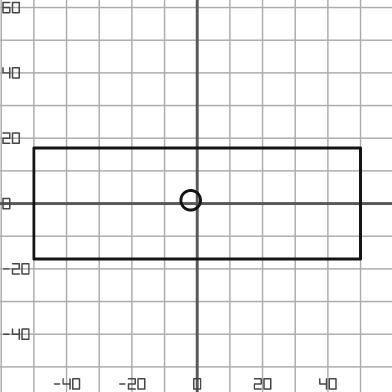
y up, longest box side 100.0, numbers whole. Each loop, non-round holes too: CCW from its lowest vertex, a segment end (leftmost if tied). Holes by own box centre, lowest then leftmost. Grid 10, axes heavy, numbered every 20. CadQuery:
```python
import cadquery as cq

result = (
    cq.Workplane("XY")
    .moveTo(-50.0, -17.0)
    .lineTo(50.0, -17.0)
    .lineTo(50.0, 17.0)
    .lineTo(-50.0, 17.0)
    .close()
    .moveTo(-2.0, 1.0)
    .circle(3.0)
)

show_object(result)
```